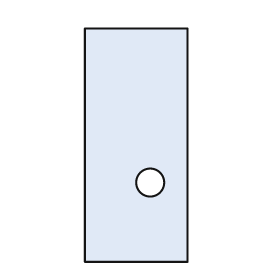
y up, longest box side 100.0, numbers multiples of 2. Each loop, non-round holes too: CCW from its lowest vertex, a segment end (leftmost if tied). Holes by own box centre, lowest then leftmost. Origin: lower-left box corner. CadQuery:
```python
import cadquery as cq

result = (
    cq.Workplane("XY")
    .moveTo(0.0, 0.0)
    .lineTo(44.0, 0.0)
    .lineTo(44.0, 100.0)
    .lineTo(0.0, 100.0)
    .close()
    .moveTo(28.0, 34.0)
    .circle(6.0)
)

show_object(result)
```